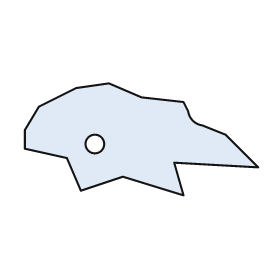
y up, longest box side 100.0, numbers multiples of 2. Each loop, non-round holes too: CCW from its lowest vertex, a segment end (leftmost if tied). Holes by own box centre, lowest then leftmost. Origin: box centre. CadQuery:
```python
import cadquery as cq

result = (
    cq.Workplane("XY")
    .moveTo(18.0, -24.0)
    .lineTo(14.0, -10.0)
    .lineTo(50.0, -12.0)
    .lineTo(36.0, 2.0)
    .lineTo(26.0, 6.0)
    .threePointArc((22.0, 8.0), (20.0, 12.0))
    .lineTo(18.0, 16.0)
    .lineTo(0.0, 18.0)
    .lineTo(-14.0, 24.0)
    .lineTo(-28.0, 22.0)
    .lineTo(-44.0, 14.0)
    .lineTo(-50.0, 4.0)
    .lineTo(-50.0, -4.0)
    .lineTo(-32.0, -8.0)
    .lineTo(-26.0, -22.0)
    .lineTo(-8.0, -16.0)
    .close()
    .moveTo(-20.0, -2.0)
    .circle(4.0)
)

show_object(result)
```